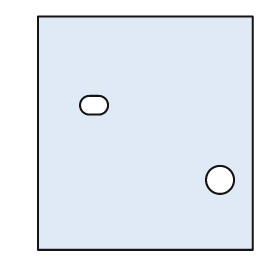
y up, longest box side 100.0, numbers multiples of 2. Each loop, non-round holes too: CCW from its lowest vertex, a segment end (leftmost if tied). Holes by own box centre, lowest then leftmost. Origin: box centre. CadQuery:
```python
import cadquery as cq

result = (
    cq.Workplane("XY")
    .moveTo(-46.0, -50.0)
    .lineTo(46.0, -50.0)
    .lineTo(46.0, 50.0)
    .lineTo(-46.0, 50.0)
    .close()
    .moveTo(32.0, -20.0)
    .circle(6.0)
    .moveTo(-24.0, 8.0)
    .lineTo(-20.0, 8.0)
    .threePointArc((-16.0, 12.0), (-20.0, 16.0))
    .lineTo(-24.0, 16.0)
    .threePointArc((-28.0, 12.0), (-24.0, 8.0))
    .close()
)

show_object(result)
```